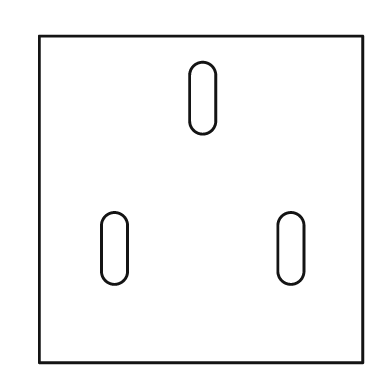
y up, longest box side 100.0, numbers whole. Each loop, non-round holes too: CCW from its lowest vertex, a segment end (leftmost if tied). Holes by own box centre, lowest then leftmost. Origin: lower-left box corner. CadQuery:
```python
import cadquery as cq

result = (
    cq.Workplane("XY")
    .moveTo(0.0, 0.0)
    .lineTo(99.0, 0.0)
    .lineTo(99.0, 100.0)
    .lineTo(0.0, 100.0)
    .close()
    .moveTo(19.0, 28.0)
    .threePointArc((23.0, 24.0), (27.0, 28.0))
    .lineTo(27.0, 42.0)
    .threePointArc((23.0, 46.0), (19.0, 42.0))
    .close()
    .moveTo(73.0, 28.0)
    .threePointArc((77.0, 24.0), (81.0, 28.0))
    .lineTo(81.0, 42.0)
    .threePointArc((77.0, 46.0), (73.0, 42.0))
    .close()
    .moveTo(46.0, 74.0)
    .threePointArc((50.0, 70.0), (54.0, 74.0))
    .lineTo(54.0, 88.0)
    .threePointArc((50.0, 92.0), (46.0, 88.0))
    .close()
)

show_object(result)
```